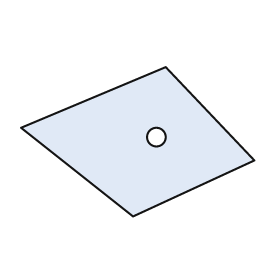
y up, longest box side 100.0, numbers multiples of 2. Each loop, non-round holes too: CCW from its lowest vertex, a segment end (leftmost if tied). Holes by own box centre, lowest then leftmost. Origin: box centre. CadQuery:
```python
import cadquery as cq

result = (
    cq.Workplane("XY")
    .moveTo(-2.0, -32.0)
    .lineTo(50.0, -8.0)
    .lineTo(12.0, 32.0)
    .lineTo(-50.0, 6.0)
    .close()
    .moveTo(8.0, 2.0)
    .circle(4.0)
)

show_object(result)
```